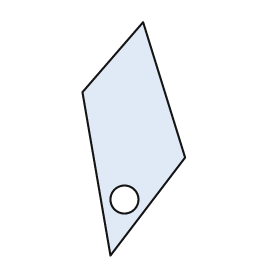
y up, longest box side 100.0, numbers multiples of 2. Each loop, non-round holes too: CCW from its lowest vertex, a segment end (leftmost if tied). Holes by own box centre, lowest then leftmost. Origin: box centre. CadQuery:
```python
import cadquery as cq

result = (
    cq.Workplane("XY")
    .moveTo(-10.0, -50.0)
    .lineTo(22.0, -8.0)
    .lineTo(4.0, 50.0)
    .lineTo(-22.0, 20.0)
    .close()
    .moveTo(-4.0, -26.0)
    .circle(6.0)
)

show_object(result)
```